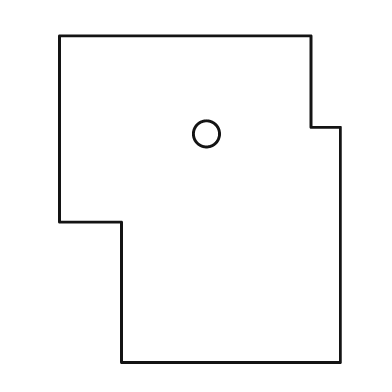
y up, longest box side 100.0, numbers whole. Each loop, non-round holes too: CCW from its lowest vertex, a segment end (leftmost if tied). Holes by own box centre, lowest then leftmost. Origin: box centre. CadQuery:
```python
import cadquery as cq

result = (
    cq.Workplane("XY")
    .moveTo(-24.0, -50.0)
    .lineTo(43.0, -50.0)
    .lineTo(43.0, 22.0)
    .lineTo(34.0, 22.0)
    .lineTo(34.0, 50.0)
    .lineTo(-43.0, 50.0)
    .lineTo(-43.0, -7.0)
    .lineTo(-24.0, -7.0)
    .close()
    .moveTo(2.0, 20.0)
    .circle(4.0)
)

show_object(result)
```